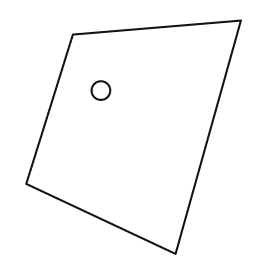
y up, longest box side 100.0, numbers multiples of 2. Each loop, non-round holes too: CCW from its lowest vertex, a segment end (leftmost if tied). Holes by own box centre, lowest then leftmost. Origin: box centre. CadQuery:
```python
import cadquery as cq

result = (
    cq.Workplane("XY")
    .moveTo(18.0, -50.0)
    .lineTo(46.0, 50.0)
    .lineTo(-26.0, 44.0)
    .lineTo(-46.0, -20.0)
    .close()
    .moveTo(-14.0, 20.0)
    .circle(4.0)
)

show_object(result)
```